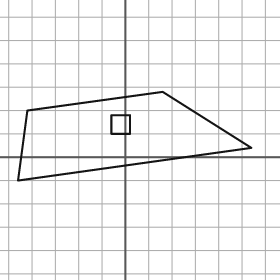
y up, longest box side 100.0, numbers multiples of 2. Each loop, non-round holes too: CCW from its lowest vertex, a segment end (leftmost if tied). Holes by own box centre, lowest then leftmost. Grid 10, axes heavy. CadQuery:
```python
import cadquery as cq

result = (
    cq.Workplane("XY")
    .moveTo(-46.0, -10.0)
    .lineTo(54.0, 4.0)
    .lineTo(16.0, 28.0)
    .lineTo(-42.0, 20.0)
    .close()
    .moveTo(-6.0, 10.0)
    .lineTo(2.0, 10.0)
    .lineTo(2.0, 18.0)
    .lineTo(-6.0, 18.0)
    .close()
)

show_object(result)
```